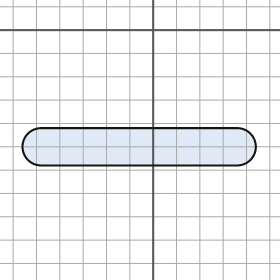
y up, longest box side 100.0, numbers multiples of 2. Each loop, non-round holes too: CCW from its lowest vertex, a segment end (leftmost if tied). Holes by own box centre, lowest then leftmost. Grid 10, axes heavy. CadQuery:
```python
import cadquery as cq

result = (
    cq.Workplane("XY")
    .moveTo(-48.0, -58.0)
    .lineTo(36.0, -58.0)
    .threePointArc((44.0, -50.0), (36.0, -42.0))
    .lineTo(-48.0, -42.0)
    .threePointArc((-56.0, -50.0), (-48.0, -58.0))
    .close()
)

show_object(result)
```